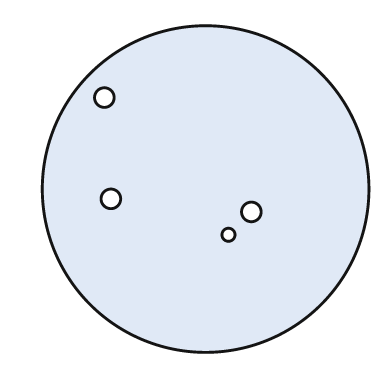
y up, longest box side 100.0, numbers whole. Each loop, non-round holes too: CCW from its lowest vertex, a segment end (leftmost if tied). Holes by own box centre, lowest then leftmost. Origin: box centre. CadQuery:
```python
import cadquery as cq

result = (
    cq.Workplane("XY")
    .moveTo(0.0, 0.0)
    .circle(50.0)
    .moveTo(7.0, -14.0)
    .circle(2.0)
    .moveTo(14.0, -7.0)
    .circle(3.0)
    .moveTo(-29.0, -3.0)
    .circle(3.0)
    .moveTo(-31.0, 28.0)
    .circle(3.0)
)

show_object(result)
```